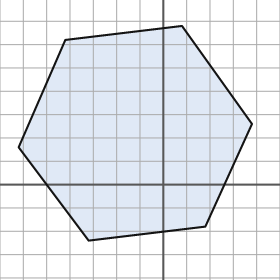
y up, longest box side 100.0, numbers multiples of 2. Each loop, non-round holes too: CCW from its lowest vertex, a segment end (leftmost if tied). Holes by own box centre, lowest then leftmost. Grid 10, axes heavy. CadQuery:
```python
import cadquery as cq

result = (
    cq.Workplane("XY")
    .moveTo(-32.0, -24.0)
    .lineTo(18.0, -18.0)
    .lineTo(38.0, 26.0)
    .lineTo(8.0, 68.0)
    .lineTo(-42.0, 62.0)
    .lineTo(-62.0, 16.0)
    .close()
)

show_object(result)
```